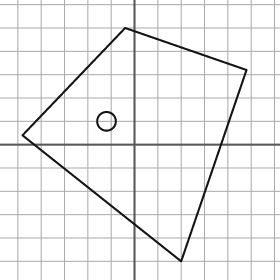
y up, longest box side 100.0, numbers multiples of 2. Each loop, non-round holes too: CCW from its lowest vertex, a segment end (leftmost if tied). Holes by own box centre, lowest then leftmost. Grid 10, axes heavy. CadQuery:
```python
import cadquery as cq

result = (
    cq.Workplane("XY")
    .moveTo(20.0, -50.0)
    .lineTo(48.0, 32.0)
    .lineTo(-4.0, 50.0)
    .lineTo(-48.0, 4.0)
    .close()
    .moveTo(-12.0, 10.0)
    .circle(4.0)
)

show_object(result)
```